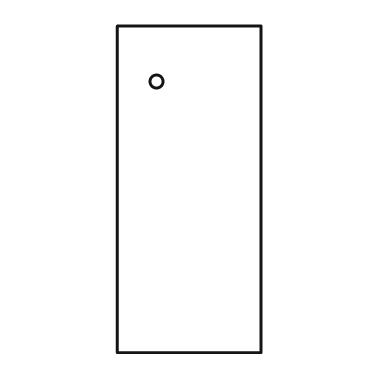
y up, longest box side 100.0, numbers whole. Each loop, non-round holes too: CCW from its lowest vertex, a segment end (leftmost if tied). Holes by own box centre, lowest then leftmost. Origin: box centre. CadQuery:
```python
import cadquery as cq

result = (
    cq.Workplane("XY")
    .moveTo(-22.0, -50.0)
    .lineTo(22.0, -50.0)
    .lineTo(22.0, 50.0)
    .lineTo(-22.0, 50.0)
    .close()
    .moveTo(-10.0, 33.0)
    .circle(2.0)
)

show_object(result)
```